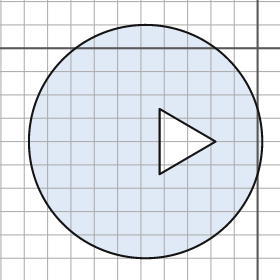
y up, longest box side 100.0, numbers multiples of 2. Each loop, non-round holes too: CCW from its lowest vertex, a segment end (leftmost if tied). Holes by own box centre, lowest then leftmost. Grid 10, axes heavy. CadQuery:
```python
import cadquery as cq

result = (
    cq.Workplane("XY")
    .moveTo(-48.0, -40.0)
    .circle(50.0)
    .moveTo(-42.0, -54.0)
    .lineTo(-18.0, -40.0)
    .lineTo(-42.0, -26.0)
    .close()
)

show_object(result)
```